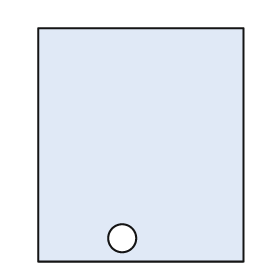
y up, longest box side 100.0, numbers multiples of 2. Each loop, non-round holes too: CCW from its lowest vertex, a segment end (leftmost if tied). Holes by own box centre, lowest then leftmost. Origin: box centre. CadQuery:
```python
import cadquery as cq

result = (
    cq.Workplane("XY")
    .moveTo(-44.0, -50.0)
    .lineTo(44.0, -50.0)
    .lineTo(44.0, 50.0)
    .lineTo(-44.0, 50.0)
    .close()
    .moveTo(-8.0, -40.0)
    .circle(6.0)
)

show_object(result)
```